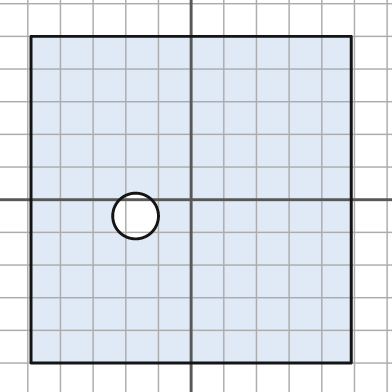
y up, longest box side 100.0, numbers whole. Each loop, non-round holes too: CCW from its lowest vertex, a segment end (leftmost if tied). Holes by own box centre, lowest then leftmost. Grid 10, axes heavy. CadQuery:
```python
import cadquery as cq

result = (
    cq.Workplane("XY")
    .moveTo(-49.0, -50.0)
    .lineTo(49.0, -50.0)
    .lineTo(49.0, 50.0)
    .lineTo(-49.0, 50.0)
    .close()
    .moveTo(-17.0, -5.0)
    .circle(7.0)
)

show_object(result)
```